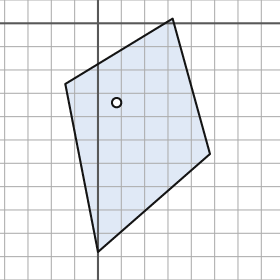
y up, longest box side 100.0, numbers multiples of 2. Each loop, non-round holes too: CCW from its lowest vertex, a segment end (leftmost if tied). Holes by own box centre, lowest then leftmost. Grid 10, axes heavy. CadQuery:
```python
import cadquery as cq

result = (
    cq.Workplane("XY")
    .moveTo(0.0, -98.0)
    .lineTo(48.0, -56.0)
    .lineTo(32.0, 2.0)
    .lineTo(-14.0, -26.0)
    .close()
    .moveTo(8.0, -34.0)
    .circle(2.0)
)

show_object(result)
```